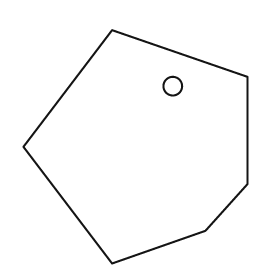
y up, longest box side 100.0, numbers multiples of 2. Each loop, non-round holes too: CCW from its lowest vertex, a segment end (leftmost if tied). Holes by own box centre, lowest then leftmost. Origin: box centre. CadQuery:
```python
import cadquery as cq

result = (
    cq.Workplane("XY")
    .moveTo(-10.0, -50.0)
    .lineTo(30.0, -36.0)
    .lineTo(48.0, -16.0)
    .lineTo(48.0, 30.0)
    .lineTo(-10.0, 50.0)
    .lineTo(-48.0, 0.0)
    .close()
    .moveTo(16.0, 26.0)
    .circle(4.0)
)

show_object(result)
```